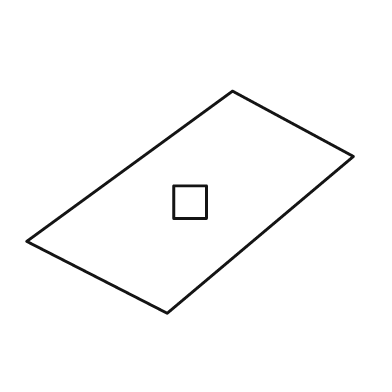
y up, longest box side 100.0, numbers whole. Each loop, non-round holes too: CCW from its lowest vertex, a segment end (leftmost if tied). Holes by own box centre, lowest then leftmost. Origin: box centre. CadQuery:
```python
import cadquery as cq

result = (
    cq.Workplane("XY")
    .moveTo(-7.0, -34.0)
    .lineTo(50.0, 14.0)
    .lineTo(13.0, 34.0)
    .lineTo(-50.0, -12.0)
    .close()
    .moveTo(-5.0, -5.0)
    .lineTo(5.0, -5.0)
    .lineTo(5.0, 5.0)
    .lineTo(-5.0, 5.0)
    .close()
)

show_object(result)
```